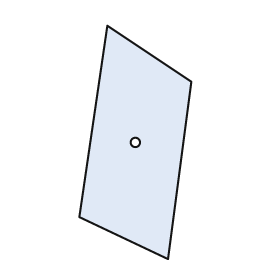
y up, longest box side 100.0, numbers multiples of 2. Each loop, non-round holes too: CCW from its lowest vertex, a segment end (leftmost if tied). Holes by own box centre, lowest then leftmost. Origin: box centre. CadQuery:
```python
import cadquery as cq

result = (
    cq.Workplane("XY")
    .moveTo(14.0, -50.0)
    .lineTo(24.0, 26.0)
    .lineTo(-12.0, 50.0)
    .lineTo(-24.0, -32.0)
    .close()
    .moveTo(0.0, 0.0)
    .circle(2.0)
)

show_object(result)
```